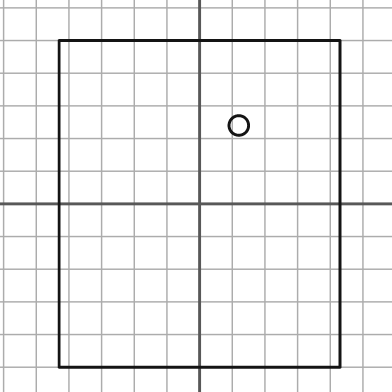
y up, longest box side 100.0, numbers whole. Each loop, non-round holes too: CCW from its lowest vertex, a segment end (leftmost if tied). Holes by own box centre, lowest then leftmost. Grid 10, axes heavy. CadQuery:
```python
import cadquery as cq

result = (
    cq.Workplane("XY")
    .moveTo(-43.0, -50.0)
    .lineTo(43.0, -50.0)
    .lineTo(43.0, 50.0)
    .lineTo(-43.0, 50.0)
    .close()
    .moveTo(12.0, 24.0)
    .circle(3.0)
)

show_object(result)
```